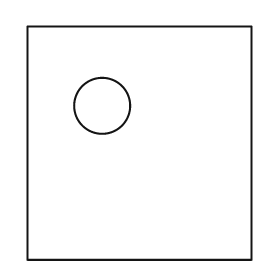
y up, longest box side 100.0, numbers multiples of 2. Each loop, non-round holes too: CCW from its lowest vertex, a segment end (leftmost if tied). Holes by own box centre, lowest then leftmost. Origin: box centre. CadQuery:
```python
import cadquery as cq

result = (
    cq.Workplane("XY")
    .moveTo(-48.0, -50.0)
    .lineTo(48.0, -50.0)
    .lineTo(48.0, 50.0)
    .lineTo(-48.0, 50.0)
    .close()
    .moveTo(-16.0, 16.0)
    .circle(12.0)
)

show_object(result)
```